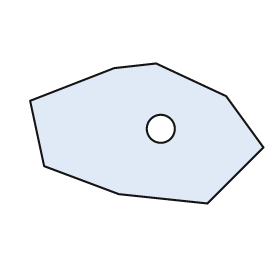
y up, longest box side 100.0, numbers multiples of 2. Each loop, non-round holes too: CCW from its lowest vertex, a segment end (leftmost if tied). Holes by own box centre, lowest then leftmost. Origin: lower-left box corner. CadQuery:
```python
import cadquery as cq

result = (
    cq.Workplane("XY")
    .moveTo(76.0, 0.0)
    .lineTo(100.0, 24.0)
    .lineTo(84.0, 46.0)
    .lineTo(54.0, 60.0)
    .lineTo(36.0, 58.0)
    .lineTo(0.0, 44.0)
    .lineTo(6.0, 16.0)
    .lineTo(38.0, 4.0)
    .close()
    .moveTo(56.0, 32.0)
    .circle(6.0)
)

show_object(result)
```